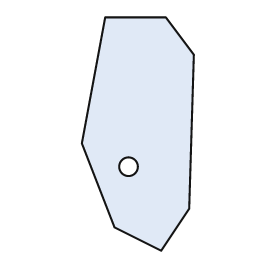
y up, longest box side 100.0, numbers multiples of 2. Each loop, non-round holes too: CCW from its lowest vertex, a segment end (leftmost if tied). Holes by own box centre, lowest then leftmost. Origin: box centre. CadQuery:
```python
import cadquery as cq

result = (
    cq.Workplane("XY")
    .moveTo(10.0, -50.0)
    .lineTo(22.0, -32.0)
    .lineTo(24.0, 34.0)
    .lineTo(12.0, 50.0)
    .lineTo(-14.0, 50.0)
    .lineTo(-24.0, -4.0)
    .lineTo(-10.0, -40.0)
    .close()
    .moveTo(-4.0, -14.0)
    .circle(4.0)
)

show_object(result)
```